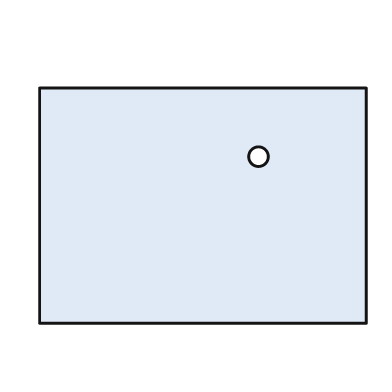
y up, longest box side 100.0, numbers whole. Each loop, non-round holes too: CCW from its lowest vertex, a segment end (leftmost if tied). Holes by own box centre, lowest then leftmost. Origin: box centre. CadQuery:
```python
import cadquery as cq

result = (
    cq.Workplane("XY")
    .moveTo(-50.0, -36.0)
    .lineTo(50.0, -36.0)
    .lineTo(50.0, 36.0)
    .lineTo(-50.0, 36.0)
    .close()
    .moveTo(17.0, 15.0)
    .circle(3.0)
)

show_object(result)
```